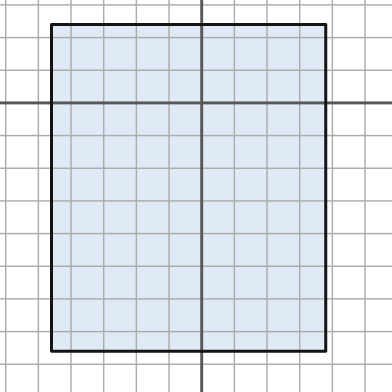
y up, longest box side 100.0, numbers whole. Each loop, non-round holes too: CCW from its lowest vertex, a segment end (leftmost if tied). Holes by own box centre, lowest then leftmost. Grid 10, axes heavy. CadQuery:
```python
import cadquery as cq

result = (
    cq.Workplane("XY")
    .moveTo(-46.0, -76.0)
    .lineTo(38.0, -76.0)
    .lineTo(38.0, 24.0)
    .lineTo(-46.0, 24.0)
    .close()
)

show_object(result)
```